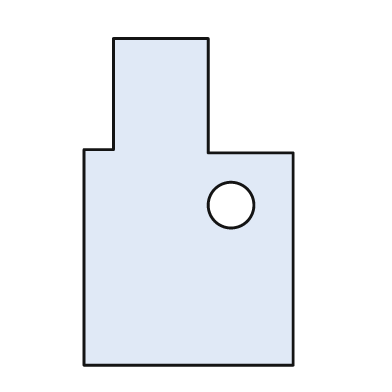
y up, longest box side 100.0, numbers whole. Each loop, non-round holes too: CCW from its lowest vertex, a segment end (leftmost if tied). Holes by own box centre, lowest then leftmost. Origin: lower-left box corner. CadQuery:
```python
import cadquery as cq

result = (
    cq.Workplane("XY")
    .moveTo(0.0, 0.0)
    .lineTo(64.0, 0.0)
    .lineTo(64.0, 65.0)
    .lineTo(38.0, 65.0)
    .lineTo(38.0, 100.0)
    .lineTo(9.0, 100.0)
    .lineTo(9.0, 66.0)
    .lineTo(0.0, 66.0)
    .close()
    .moveTo(45.0, 49.0)
    .circle(7.0)
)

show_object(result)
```